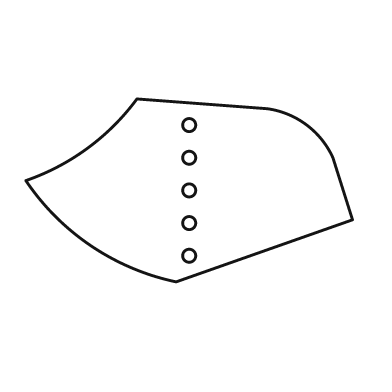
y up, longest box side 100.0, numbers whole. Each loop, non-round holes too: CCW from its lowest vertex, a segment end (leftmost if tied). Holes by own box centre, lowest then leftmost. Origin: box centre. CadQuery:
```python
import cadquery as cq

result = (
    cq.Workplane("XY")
    .moveTo(-4.0, -28.0)
    .lineTo(50.0, -9.0)
    .lineTo(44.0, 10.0)
    .threePointArc((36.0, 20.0), (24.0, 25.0))
    .lineTo(-16.0, 28.0)
    .threePointArc((-31.0, 13.0), (-50.0, 3.0))
    .threePointArc((-30.0, -17.0), (-4.0, -28.0))
    .close()
    .moveTo(0.0, -20.0)
    .circle(2.0)
    .moveTo(0.0, -10.0)
    .circle(2.0)
    .moveTo(0.0, 0.0)
    .circle(2.0)
    .moveTo(0.0, 10.0)
    .circle(2.0)
    .moveTo(0.0, 20.0)
    .circle(2.0)
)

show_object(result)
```